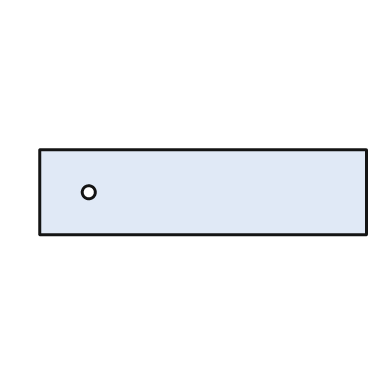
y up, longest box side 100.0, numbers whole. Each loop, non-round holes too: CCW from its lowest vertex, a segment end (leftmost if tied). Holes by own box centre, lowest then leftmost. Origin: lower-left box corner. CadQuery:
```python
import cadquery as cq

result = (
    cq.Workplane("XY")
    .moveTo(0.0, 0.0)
    .lineTo(100.0, 0.0)
    .lineTo(100.0, 26.0)
    .lineTo(0.0, 26.0)
    .close()
    .moveTo(15.0, 13.0)
    .circle(2.0)
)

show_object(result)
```